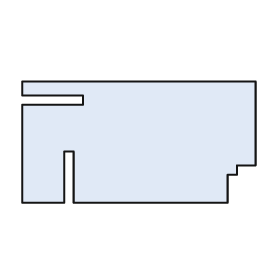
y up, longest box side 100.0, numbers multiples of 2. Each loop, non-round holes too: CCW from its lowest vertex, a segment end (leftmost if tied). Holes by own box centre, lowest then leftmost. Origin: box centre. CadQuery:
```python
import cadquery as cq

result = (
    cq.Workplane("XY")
    .moveTo(-50.0, -26.0)
    .lineTo(-32.0, -26.0)
    .lineTo(-32.0, -4.0)
    .lineTo(-28.0, -4.0)
    .lineTo(-28.0, -26.0)
    .lineTo(38.0, -26.0)
    .lineTo(38.0, -14.0)
    .lineTo(42.0, -14.0)
    .lineTo(42.0, -10.0)
    .lineTo(50.0, -10.0)
    .lineTo(50.0, 26.0)
    .lineTo(-50.0, 26.0)
    .lineTo(-50.0, 20.0)
    .lineTo(-24.0, 20.0)
    .lineTo(-24.0, 16.0)
    .lineTo(-50.0, 16.0)
    .close()
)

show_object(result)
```